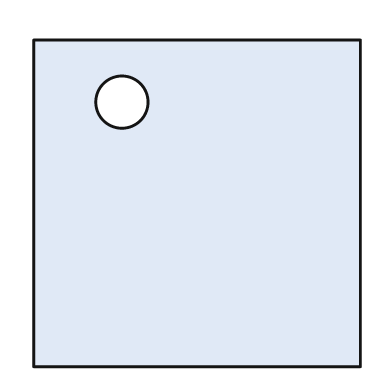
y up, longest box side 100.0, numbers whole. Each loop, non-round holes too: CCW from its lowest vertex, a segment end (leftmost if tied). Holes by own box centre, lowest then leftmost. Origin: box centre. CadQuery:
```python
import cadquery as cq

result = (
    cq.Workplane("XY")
    .moveTo(-50.0, -50.0)
    .lineTo(50.0, -50.0)
    .lineTo(50.0, 50.0)
    .lineTo(-50.0, 50.0)
    .close()
    .moveTo(-23.0, 31.0)
    .circle(8.0)
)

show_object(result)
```